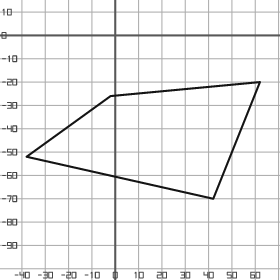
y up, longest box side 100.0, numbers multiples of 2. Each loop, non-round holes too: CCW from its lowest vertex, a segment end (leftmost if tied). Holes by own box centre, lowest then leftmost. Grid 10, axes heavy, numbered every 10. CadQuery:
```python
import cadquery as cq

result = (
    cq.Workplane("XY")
    .moveTo(42.0, -70.0)
    .lineTo(62.0, -20.0)
    .lineTo(-2.0, -26.0)
    .lineTo(-38.0, -52.0)
    .close()
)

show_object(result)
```